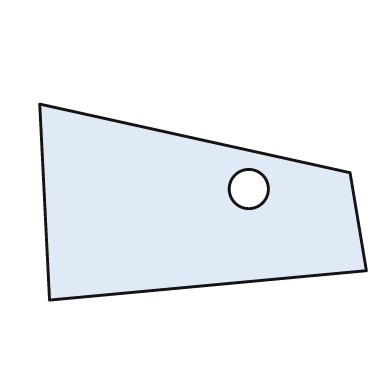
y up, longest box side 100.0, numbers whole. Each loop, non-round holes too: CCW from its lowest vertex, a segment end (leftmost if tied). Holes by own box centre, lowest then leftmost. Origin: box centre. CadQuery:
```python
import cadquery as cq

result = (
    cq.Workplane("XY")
    .moveTo(-47.0, -30.0)
    .lineTo(50.0, -21.0)
    .lineTo(45.0, 9.0)
    .lineTo(-50.0, 30.0)
    .close()
    .moveTo(14.0, 4.0)
    .circle(6.0)
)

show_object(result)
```